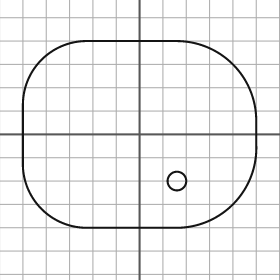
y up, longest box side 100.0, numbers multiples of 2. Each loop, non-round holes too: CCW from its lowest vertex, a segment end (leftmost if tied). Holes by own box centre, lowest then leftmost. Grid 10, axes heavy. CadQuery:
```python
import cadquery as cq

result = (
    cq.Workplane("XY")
    .moveTo(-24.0, -40.0)
    .lineTo(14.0, -40.0)
    .threePointArc((40.0, -30.0), (50.0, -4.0))
    .lineTo(50.0, 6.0)
    .threePointArc((40.0, 30.0), (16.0, 40.0))
    .lineTo(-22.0, 40.0)
    .threePointArc((-42.0, 32.0), (-50.0, 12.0))
    .lineTo(-50.0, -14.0)
    .threePointArc((-42.0, -32.0), (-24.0, -40.0))
    .close()
    .moveTo(16.0, -20.0)
    .circle(4.0)
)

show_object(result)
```